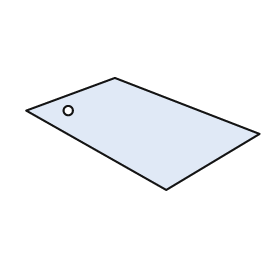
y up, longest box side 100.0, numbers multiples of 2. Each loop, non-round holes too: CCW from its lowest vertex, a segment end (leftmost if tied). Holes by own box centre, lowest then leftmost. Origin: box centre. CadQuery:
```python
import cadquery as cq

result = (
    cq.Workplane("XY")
    .moveTo(10.0, -24.0)
    .lineTo(50.0, 0.0)
    .lineTo(-12.0, 24.0)
    .lineTo(-50.0, 10.0)
    .close()
    .moveTo(-32.0, 10.0)
    .circle(2.0)
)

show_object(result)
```